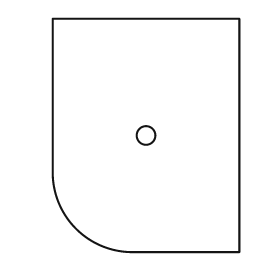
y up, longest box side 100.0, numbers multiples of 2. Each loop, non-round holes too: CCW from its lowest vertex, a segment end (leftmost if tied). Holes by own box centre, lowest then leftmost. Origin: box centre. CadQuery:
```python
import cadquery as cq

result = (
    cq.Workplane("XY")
    .moveTo(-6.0, -50.0)
    .lineTo(40.0, -50.0)
    .lineTo(40.0, 50.0)
    .lineTo(-40.0, 50.0)
    .lineTo(-40.0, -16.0)
    .threePointArc((-30.0, -40.0), (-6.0, -50.0))
    .close()
    .moveTo(0.0, 0.0)
    .circle(4.0)
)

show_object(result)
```